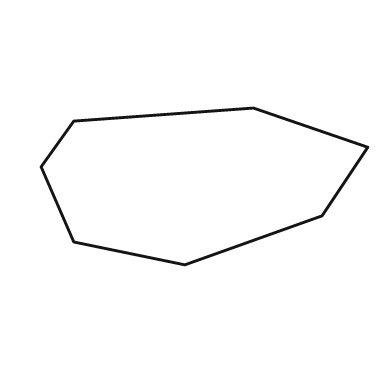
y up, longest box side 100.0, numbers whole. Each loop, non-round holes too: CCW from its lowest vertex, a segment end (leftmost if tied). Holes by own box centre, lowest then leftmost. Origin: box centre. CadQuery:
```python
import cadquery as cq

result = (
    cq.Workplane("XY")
    .moveTo(-6.0, -24.0)
    .lineTo(36.0, -9.0)
    .lineTo(50.0, 12.0)
    .lineTo(15.0, 24.0)
    .lineTo(-40.0, 20.0)
    .lineTo(-50.0, 6.0)
    .lineTo(-40.0, -17.0)
    .close()
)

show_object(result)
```